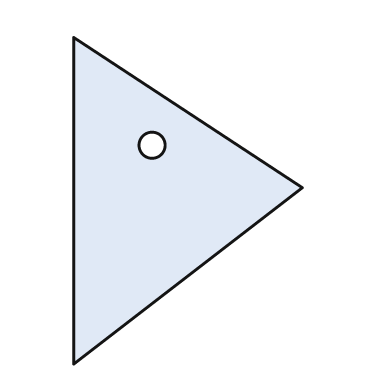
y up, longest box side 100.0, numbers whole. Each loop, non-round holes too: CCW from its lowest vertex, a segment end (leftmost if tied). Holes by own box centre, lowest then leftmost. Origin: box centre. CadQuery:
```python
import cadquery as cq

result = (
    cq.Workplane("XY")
    .moveTo(-35.0, -50.0)
    .lineTo(35.0, 4.0)
    .lineTo(-35.0, 50.0)
    .close()
    .moveTo(-11.0, 17.0)
    .circle(4.0)
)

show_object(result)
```